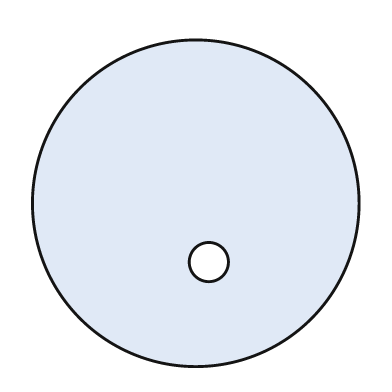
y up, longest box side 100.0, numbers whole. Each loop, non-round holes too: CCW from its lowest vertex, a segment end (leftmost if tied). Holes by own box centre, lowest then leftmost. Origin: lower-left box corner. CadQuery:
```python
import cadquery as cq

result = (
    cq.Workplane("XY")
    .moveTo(50.0, 50.0)
    .circle(50.0)
    .moveTo(54.0, 32.0)
    .circle(6.0)
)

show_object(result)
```